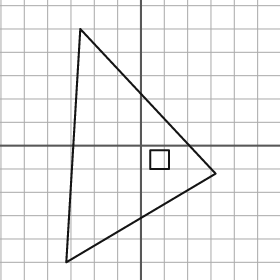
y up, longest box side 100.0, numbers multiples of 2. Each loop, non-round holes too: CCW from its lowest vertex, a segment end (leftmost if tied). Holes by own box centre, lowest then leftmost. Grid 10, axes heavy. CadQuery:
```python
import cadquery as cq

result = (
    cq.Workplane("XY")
    .moveTo(-32.0, -50.0)
    .lineTo(32.0, -12.0)
    .lineTo(-26.0, 50.0)
    .close()
    .moveTo(4.0, -10.0)
    .lineTo(12.0, -10.0)
    .lineTo(12.0, -2.0)
    .lineTo(4.0, -2.0)
    .close()
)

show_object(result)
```